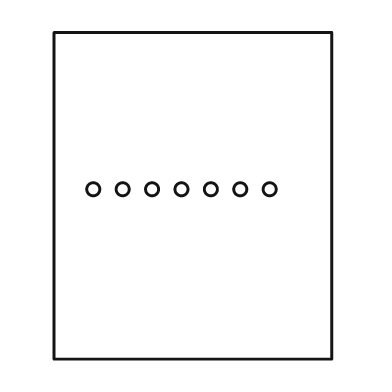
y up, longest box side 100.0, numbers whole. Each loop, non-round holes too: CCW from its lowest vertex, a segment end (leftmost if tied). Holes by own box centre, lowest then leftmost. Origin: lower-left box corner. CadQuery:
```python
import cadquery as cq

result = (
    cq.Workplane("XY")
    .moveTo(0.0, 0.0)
    .lineTo(85.0, 0.0)
    .lineTo(85.0, 100.0)
    .lineTo(0.0, 100.0)
    .close()
    .moveTo(12.0, 52.0)
    .circle(2.0)
    .moveTo(21.0, 52.0)
    .circle(2.0)
    .moveTo(30.0, 52.0)
    .circle(2.0)
    .moveTo(39.0, 52.0)
    .circle(2.0)
    .moveTo(48.0, 52.0)
    .circle(2.0)
    .moveTo(57.0, 52.0)
    .circle(2.0)
    .moveTo(66.0, 52.0)
    .circle(2.0)
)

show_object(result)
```